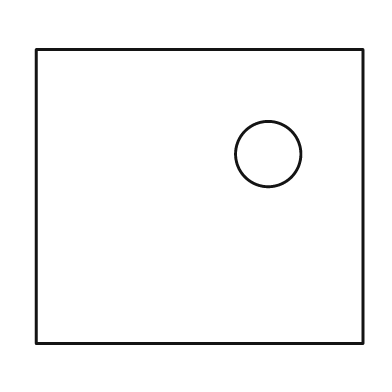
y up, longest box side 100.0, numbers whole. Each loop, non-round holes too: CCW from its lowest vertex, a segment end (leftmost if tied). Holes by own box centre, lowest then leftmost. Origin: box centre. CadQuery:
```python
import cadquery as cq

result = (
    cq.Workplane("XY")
    .moveTo(-50.0, -45.0)
    .lineTo(50.0, -45.0)
    .lineTo(50.0, 45.0)
    .lineTo(-50.0, 45.0)
    .close()
    .moveTo(21.0, 13.0)
    .circle(10.0)
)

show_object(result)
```